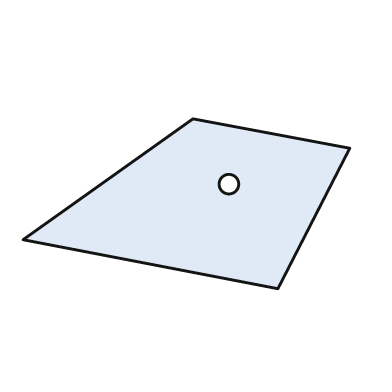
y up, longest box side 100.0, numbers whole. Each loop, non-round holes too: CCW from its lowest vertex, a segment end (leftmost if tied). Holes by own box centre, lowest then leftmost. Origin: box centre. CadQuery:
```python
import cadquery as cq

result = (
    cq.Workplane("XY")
    .moveTo(28.0, -26.0)
    .lineTo(50.0, 17.0)
    .lineTo(2.0, 26.0)
    .lineTo(-50.0, -11.0)
    .close()
    .moveTo(13.0, 6.0)
    .circle(3.0)
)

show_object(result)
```